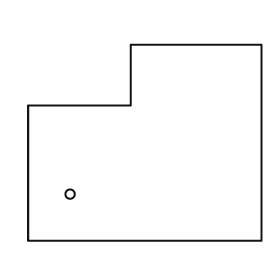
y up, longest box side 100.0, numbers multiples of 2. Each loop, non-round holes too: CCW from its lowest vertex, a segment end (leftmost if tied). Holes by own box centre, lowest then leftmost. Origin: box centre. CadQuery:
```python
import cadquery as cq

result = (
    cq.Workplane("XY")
    .moveTo(-50.0, -42.0)
    .lineTo(50.0, -42.0)
    .lineTo(50.0, 42.0)
    .lineTo(-6.0, 42.0)
    .lineTo(-6.0, 16.0)
    .lineTo(-50.0, 16.0)
    .close()
    .moveTo(-32.0, -22.0)
    .circle(2.0)
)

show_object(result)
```